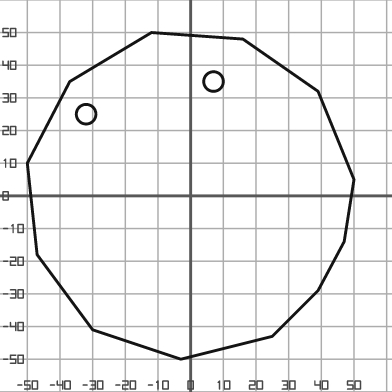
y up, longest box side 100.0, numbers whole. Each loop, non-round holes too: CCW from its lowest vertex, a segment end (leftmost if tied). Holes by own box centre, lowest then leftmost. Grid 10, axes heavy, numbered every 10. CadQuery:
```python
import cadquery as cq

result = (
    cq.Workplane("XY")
    .moveTo(-3.0, -50.0)
    .lineTo(25.0, -43.0)
    .lineTo(39.0, -29.0)
    .lineTo(47.0, -14.0)
    .lineTo(50.0, 5.0)
    .lineTo(39.0, 32.0)
    .lineTo(16.0, 48.0)
    .lineTo(-12.0, 50.0)
    .lineTo(-37.0, 35.0)
    .lineTo(-50.0, 10.0)
    .lineTo(-47.0, -18.0)
    .lineTo(-30.0, -41.0)
    .close()
    .moveTo(-32.0, 25.0)
    .circle(3.0)
    .moveTo(7.0, 35.0)
    .circle(3.0)
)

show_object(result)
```